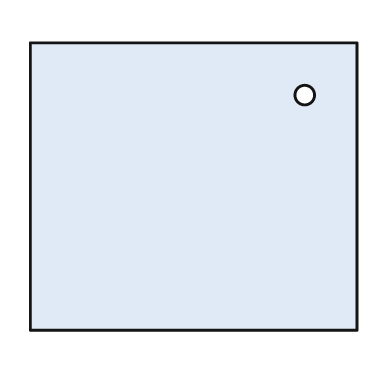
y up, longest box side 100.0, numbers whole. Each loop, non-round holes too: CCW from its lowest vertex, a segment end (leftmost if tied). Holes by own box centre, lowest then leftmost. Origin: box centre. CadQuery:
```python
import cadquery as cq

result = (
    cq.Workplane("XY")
    .moveTo(-50.0, -44.0)
    .lineTo(50.0, -44.0)
    .lineTo(50.0, 44.0)
    .lineTo(-50.0, 44.0)
    .close()
    .moveTo(34.0, 28.0)
    .circle(3.0)
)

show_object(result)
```